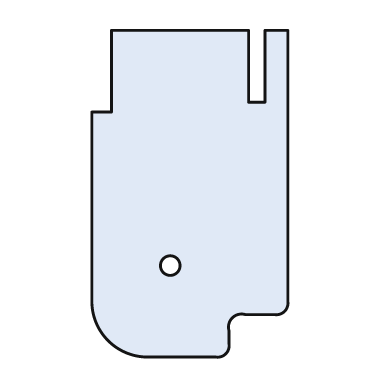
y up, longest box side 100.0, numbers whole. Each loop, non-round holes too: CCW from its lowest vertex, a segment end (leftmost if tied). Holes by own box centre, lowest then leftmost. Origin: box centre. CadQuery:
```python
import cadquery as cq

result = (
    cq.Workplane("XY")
    .moveTo(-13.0, -50.0)
    .lineTo(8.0, -50.0)
    .threePointArc((11.0, -49.0), (12.0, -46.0))
    .lineTo(12.0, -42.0)
    .threePointArc((13.0, -38.0), (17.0, -37.0))
    .lineTo(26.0, -37.0)
    .threePointArc((29.0, -36.0), (30.0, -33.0))
    .lineTo(30.0, 50.0)
    .lineTo(23.0, 50.0)
    .lineTo(23.0, 28.0)
    .lineTo(18.0, 28.0)
    .lineTo(18.0, 50.0)
    .lineTo(-24.0, 50.0)
    .lineTo(-24.0, 25.0)
    .lineTo(-30.0, 25.0)
    .lineTo(-30.0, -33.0)
    .threePointArc((-25.0, -45.0), (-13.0, -50.0))
    .close()
    .moveTo(-6.0, -22.0)
    .circle(3.0)
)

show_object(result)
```